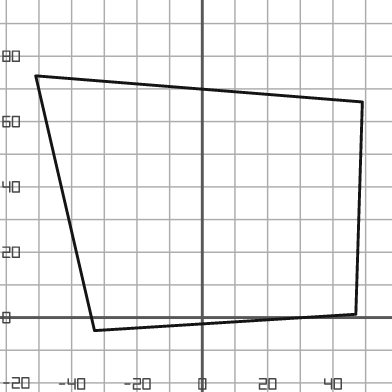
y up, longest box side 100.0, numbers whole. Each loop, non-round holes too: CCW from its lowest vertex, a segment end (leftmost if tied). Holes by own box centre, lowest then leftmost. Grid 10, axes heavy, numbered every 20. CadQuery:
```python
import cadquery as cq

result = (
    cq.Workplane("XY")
    .moveTo(-33.0, -4.0)
    .lineTo(47.0, 1.0)
    .lineTo(49.0, 66.0)
    .lineTo(-51.0, 74.0)
    .close()
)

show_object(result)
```